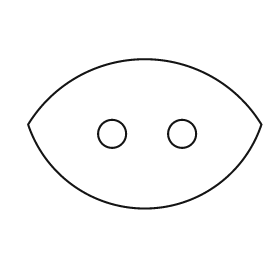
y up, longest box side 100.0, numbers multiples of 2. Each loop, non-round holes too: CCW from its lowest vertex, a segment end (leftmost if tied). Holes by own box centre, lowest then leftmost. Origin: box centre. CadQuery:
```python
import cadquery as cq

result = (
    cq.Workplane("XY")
    .moveTo(-50.0, 4.0)
    .threePointArc((0.0, -32.0), (50.0, 4.0))
    .threePointArc((0.0, 32.0), (-50.0, 4.0))
    .close()
    .moveTo(-14.0, 0.0)
    .circle(6.0)
    .moveTo(16.0, 0.0)
    .circle(6.0)
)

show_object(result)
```